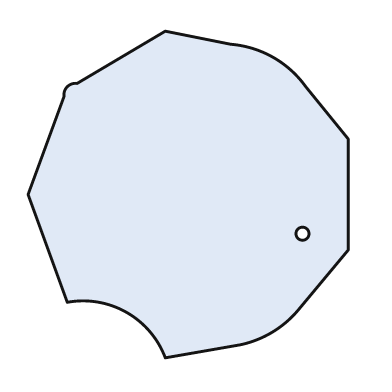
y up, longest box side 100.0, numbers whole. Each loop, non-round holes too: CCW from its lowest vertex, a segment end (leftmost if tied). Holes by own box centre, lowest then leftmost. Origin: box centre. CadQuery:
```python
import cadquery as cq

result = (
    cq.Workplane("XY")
    .moveTo(-7.0, -50.0)
    .lineTo(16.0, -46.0)
    .threePointArc((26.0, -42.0), (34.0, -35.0))
    .lineTo(49.0, -17.0)
    .lineTo(49.0, 17.0)
    .lineTo(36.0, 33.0)
    .threePointArc((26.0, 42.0), (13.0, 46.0))
    .lineTo(-7.0, 50.0)
    .lineTo(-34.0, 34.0)
    .threePointArc((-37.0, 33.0), (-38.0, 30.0))
    .lineTo(-49.0, 0.0)
    .lineTo(-37.0, -33.0)
    .threePointArc((-19.0, -36.0), (-7.0, -50.0))
    .close()
    .moveTo(35.0, -12.0)
    .circle(2.0)
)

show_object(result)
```